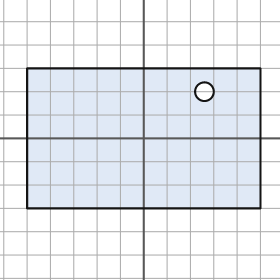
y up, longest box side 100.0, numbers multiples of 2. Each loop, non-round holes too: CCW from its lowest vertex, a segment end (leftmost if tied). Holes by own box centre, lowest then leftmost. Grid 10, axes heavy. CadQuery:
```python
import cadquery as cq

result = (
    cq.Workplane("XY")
    .moveTo(-50.0, -30.0)
    .lineTo(50.0, -30.0)
    .lineTo(50.0, 30.0)
    .lineTo(-50.0, 30.0)
    .close()
    .moveTo(26.0, 20.0)
    .circle(4.0)
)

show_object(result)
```